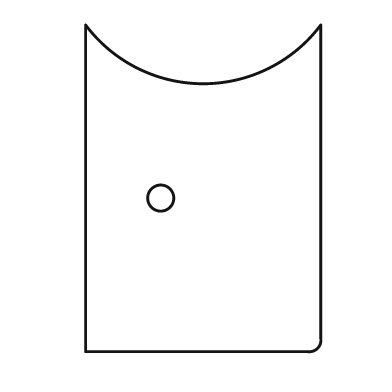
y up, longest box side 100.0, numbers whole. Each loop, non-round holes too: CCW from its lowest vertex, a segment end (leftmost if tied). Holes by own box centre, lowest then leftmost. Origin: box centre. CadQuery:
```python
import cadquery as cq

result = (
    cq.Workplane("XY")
    .moveTo(-36.0, -50.0)
    .lineTo(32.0, -50.0)
    .threePointArc((35.0, -49.0), (36.0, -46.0))
    .lineTo(36.0, 50.0)
    .threePointArc((0.0, 32.0), (-36.0, 50.0))
    .close()
    .moveTo(-13.0, -3.0)
    .circle(4.0)
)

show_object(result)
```